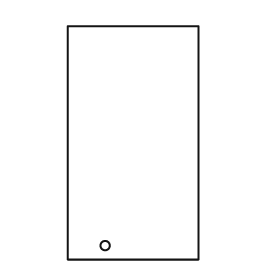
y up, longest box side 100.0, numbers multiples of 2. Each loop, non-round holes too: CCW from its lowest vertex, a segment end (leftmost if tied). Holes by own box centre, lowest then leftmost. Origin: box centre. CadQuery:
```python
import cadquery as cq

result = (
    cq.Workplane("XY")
    .moveTo(-28.0, -50.0)
    .lineTo(28.0, -50.0)
    .lineTo(28.0, 50.0)
    .lineTo(-28.0, 50.0)
    .close()
    .moveTo(-12.0, -44.0)
    .circle(2.0)
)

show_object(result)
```